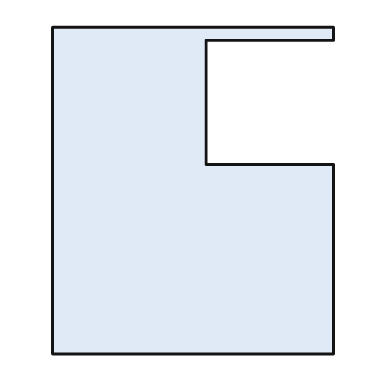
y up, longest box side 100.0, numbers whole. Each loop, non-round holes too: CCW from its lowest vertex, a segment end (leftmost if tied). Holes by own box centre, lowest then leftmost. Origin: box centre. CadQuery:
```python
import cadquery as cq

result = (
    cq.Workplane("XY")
    .moveTo(-43.0, -50.0)
    .lineTo(43.0, -50.0)
    .lineTo(43.0, 8.0)
    .lineTo(4.0, 8.0)
    .lineTo(4.0, 46.0)
    .lineTo(43.0, 46.0)
    .lineTo(43.0, 50.0)
    .lineTo(-43.0, 50.0)
    .close()
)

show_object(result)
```